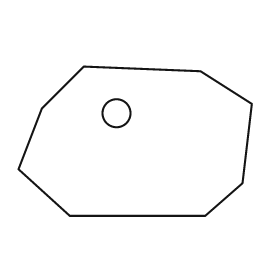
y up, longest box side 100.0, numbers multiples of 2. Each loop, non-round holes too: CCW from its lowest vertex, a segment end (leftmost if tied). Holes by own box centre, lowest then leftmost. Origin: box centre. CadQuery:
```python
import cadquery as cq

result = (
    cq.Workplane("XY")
    .moveTo(-28.0, -32.0)
    .lineTo(30.0, -32.0)
    .lineTo(46.0, -18.0)
    .lineTo(50.0, 16.0)
    .lineTo(28.0, 30.0)
    .lineTo(-22.0, 32.0)
    .lineTo(-40.0, 14.0)
    .lineTo(-50.0, -12.0)
    .close()
    .moveTo(-8.0, 12.0)
    .circle(6.0)
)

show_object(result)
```